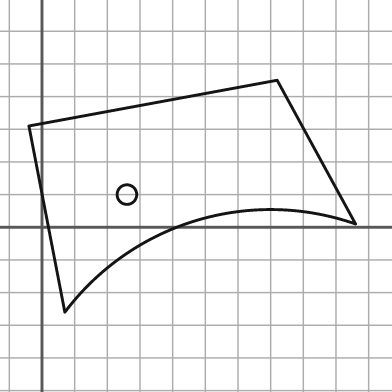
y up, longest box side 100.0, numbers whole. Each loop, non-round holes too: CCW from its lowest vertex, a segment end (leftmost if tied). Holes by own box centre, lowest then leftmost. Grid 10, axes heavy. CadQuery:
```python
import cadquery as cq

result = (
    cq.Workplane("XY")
    .moveTo(7.0, -26.0)
    .threePointArc((47.0, 2.0), (96.0, 1.0))
    .lineTo(72.0, 45.0)
    .lineTo(-4.0, 31.0)
    .close()
    .moveTo(26.0, 10.0)
    .circle(3.0)
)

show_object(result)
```